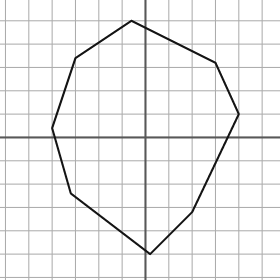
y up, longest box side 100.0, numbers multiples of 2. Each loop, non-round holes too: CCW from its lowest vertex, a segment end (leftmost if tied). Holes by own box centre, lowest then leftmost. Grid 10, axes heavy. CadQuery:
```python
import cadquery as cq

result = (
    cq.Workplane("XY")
    .moveTo(2.0, -50.0)
    .lineTo(20.0, -32.0)
    .lineTo(40.0, 10.0)
    .lineTo(30.0, 32.0)
    .lineTo(-6.0, 50.0)
    .lineTo(-30.0, 34.0)
    .lineTo(-40.0, 4.0)
    .lineTo(-32.0, -24.0)
    .close()
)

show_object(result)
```